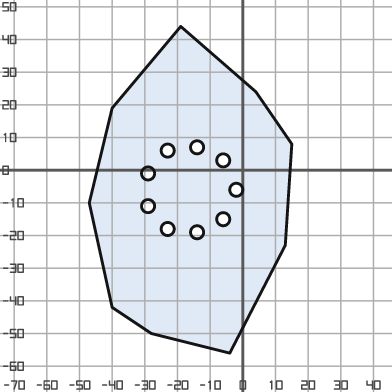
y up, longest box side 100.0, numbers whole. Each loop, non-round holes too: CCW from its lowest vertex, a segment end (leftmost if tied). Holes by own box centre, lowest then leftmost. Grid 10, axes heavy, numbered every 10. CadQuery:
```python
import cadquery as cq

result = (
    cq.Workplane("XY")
    .moveTo(-4.0, -56.0)
    .lineTo(13.0, -23.0)
    .lineTo(15.0, 8.0)
    .lineTo(4.0, 24.0)
    .lineTo(-19.0, 44.0)
    .lineTo(-40.0, 19.0)
    .lineTo(-47.0, -10.0)
    .lineTo(-40.0, -42.0)
    .lineTo(-28.0, -50.0)
    .close()
    .moveTo(-14.0, -19.0)
    .circle(2.0)
    .moveTo(-23.0, -18.0)
    .circle(2.0)
    .moveTo(-6.0, -15.0)
    .circle(2.0)
    .moveTo(-29.0, -11.0)
    .circle(2.0)
    .moveTo(-2.0, -6.0)
    .circle(2.0)
    .moveTo(-29.0, -1.0)
    .circle(2.0)
    .moveTo(-6.0, 3.0)
    .circle(2.0)
    .moveTo(-23.0, 6.0)
    .circle(2.0)
    .moveTo(-14.0, 7.0)
    .circle(2.0)
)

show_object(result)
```